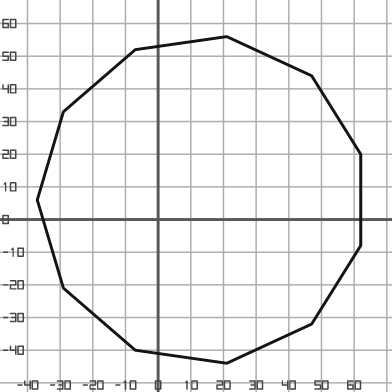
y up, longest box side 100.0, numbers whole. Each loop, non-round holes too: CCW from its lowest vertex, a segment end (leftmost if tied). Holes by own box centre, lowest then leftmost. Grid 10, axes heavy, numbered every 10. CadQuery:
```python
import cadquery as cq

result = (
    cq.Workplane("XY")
    .moveTo(21.0, -44.0)
    .lineTo(47.0, -32.0)
    .lineTo(62.0, -8.0)
    .lineTo(62.0, 20.0)
    .lineTo(47.0, 44.0)
    .lineTo(21.0, 56.0)
    .lineTo(-7.0, 52.0)
    .lineTo(-29.0, 33.0)
    .lineTo(-37.0, 6.0)
    .lineTo(-29.0, -21.0)
    .lineTo(-7.0, -40.0)
    .close()
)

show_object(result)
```